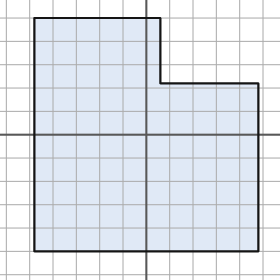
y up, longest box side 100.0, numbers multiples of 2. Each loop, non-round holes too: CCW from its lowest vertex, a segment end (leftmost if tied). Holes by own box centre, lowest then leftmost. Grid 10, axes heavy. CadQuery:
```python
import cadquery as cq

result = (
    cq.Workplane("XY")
    .moveTo(-48.0, -50.0)
    .lineTo(48.0, -50.0)
    .lineTo(48.0, 22.0)
    .lineTo(6.0, 22.0)
    .lineTo(6.0, 50.0)
    .lineTo(-48.0, 50.0)
    .close()
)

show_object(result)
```